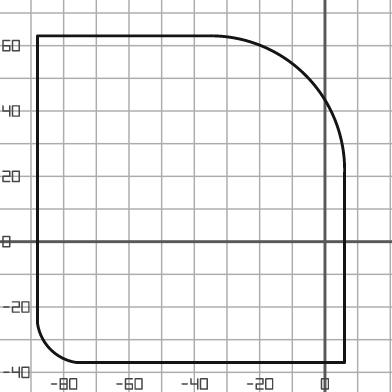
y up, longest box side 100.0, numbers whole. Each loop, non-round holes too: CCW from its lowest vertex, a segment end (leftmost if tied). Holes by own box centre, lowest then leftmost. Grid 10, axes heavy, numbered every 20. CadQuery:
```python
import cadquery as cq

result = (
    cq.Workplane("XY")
    .moveTo(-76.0, -37.0)
    .lineTo(6.0, -37.0)
    .lineTo(6.0, 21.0)
    .threePointArc((-6.0, 51.0), (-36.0, 63.0))
    .lineTo(-88.0, 63.0)
    .lineTo(-88.0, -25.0)
    .threePointArc((-84.0, -33.0), (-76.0, -37.0))
    .close()
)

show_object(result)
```